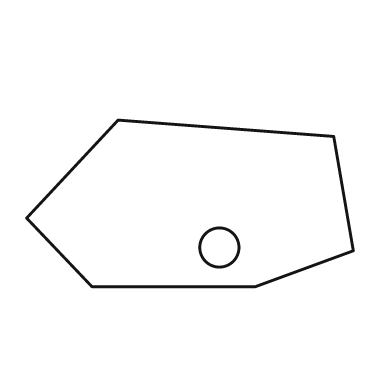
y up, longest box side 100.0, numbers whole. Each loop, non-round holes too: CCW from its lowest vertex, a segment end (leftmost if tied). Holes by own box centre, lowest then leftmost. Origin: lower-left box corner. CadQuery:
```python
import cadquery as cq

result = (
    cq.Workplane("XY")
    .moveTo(20.0, 0.0)
    .lineTo(70.0, 0.0)
    .lineTo(100.0, 11.0)
    .lineTo(94.0, 46.0)
    .lineTo(28.0, 51.0)
    .lineTo(0.0, 21.0)
    .close()
    .moveTo(59.0, 12.0)
    .circle(6.0)
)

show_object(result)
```